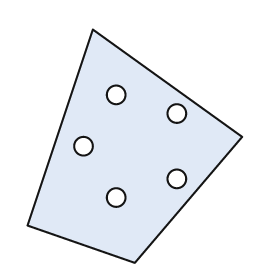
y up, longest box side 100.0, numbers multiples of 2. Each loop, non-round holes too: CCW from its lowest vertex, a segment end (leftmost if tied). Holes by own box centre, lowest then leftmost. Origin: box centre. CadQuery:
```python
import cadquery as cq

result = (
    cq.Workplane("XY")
    .moveTo(0.0, -50.0)
    .lineTo(46.0, 4.0)
    .lineTo(-18.0, 50.0)
    .lineTo(-46.0, -34.0)
    .close()
    .moveTo(-8.0, -22.0)
    .circle(4.0)
    .moveTo(18.0, -14.0)
    .circle(4.0)
    .moveTo(-22.0, 0.0)
    .circle(4.0)
    .moveTo(18.0, 14.0)
    .circle(4.0)
    .moveTo(-8.0, 22.0)
    .circle(4.0)
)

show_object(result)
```